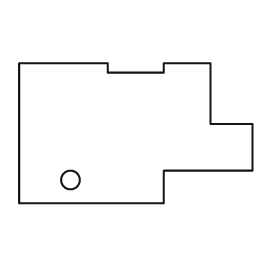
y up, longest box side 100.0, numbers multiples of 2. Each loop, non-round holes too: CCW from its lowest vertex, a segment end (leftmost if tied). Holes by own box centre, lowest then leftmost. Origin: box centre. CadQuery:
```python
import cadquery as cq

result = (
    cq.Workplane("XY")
    .moveTo(-50.0, -30.0)
    .lineTo(12.0, -30.0)
    .lineTo(12.0, -16.0)
    .lineTo(50.0, -16.0)
    .lineTo(50.0, 4.0)
    .lineTo(32.0, 4.0)
    .lineTo(32.0, 30.0)
    .lineTo(12.0, 30.0)
    .lineTo(12.0, 26.0)
    .lineTo(-12.0, 26.0)
    .lineTo(-12.0, 30.0)
    .lineTo(-50.0, 30.0)
    .close()
    .moveTo(-28.0, -20.0)
    .circle(4.0)
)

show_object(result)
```